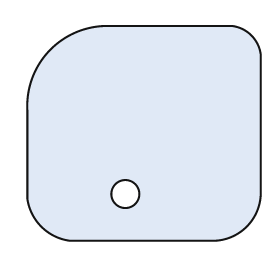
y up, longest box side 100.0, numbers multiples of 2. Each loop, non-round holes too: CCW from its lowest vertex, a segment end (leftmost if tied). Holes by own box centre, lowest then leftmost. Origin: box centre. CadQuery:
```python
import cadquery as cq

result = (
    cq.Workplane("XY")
    .moveTo(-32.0, -46.0)
    .lineTo(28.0, -46.0)
    .threePointArc((44.0, -40.0), (50.0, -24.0))
    .lineTo(50.0, 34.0)
    .threePointArc((46.0, 42.0), (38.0, 46.0))
    .lineTo(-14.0, 46.0)
    .threePointArc((-40.0, 36.0), (-50.0, 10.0))
    .lineTo(-50.0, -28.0)
    .threePointArc((-44.0, -40.0), (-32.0, -46.0))
    .close()
    .moveTo(-8.0, -26.0)
    .circle(6.0)
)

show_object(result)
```